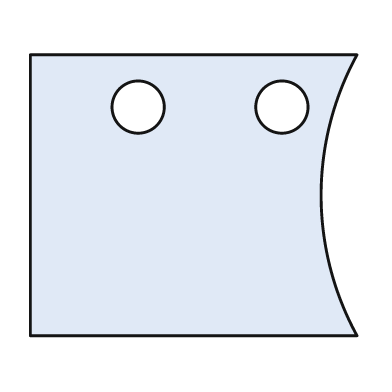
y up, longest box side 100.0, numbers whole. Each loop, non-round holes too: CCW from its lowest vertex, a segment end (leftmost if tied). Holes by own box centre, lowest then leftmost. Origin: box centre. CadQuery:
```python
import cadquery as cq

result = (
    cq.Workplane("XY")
    .moveTo(-50.0, -43.0)
    .lineTo(50.0, -43.0)
    .threePointArc((39.0, 0.0), (50.0, 43.0))
    .lineTo(-50.0, 43.0)
    .close()
    .moveTo(-17.0, 27.0)
    .circle(8.0)
    .moveTo(27.0, 27.0)
    .circle(8.0)
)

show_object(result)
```